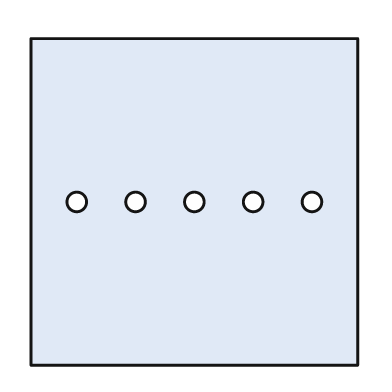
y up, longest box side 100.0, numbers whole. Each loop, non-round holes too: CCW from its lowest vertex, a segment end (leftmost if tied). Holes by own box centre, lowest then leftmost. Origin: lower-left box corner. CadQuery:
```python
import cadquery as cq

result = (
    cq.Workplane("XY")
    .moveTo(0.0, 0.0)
    .lineTo(100.0, 0.0)
    .lineTo(100.0, 100.0)
    .lineTo(0.0, 100.0)
    .close()
    .moveTo(14.0, 50.0)
    .circle(3.0)
    .moveTo(32.0, 50.0)
    .circle(3.0)
    .moveTo(50.0, 50.0)
    .circle(3.0)
    .moveTo(68.0, 50.0)
    .circle(3.0)
    .moveTo(86.0, 50.0)
    .circle(3.0)
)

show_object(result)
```